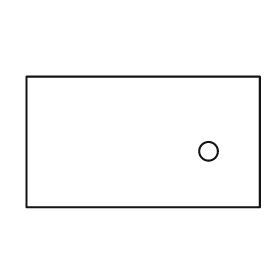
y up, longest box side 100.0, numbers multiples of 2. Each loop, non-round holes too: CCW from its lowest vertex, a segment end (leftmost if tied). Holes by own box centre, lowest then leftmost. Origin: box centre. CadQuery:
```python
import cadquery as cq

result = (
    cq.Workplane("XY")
    .moveTo(-50.0, -28.0)
    .lineTo(50.0, -28.0)
    .lineTo(50.0, 28.0)
    .lineTo(-50.0, 28.0)
    .close()
    .moveTo(28.0, -4.0)
    .circle(4.0)
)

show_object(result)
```